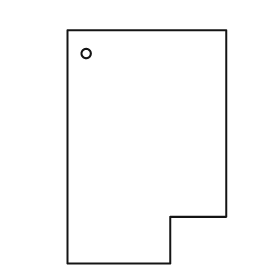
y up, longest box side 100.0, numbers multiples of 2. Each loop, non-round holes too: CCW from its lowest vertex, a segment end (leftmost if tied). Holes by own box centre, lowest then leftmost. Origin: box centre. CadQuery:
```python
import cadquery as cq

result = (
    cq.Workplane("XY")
    .moveTo(-34.0, -50.0)
    .lineTo(10.0, -50.0)
    .lineTo(10.0, -30.0)
    .lineTo(34.0, -30.0)
    .lineTo(34.0, 50.0)
    .lineTo(-34.0, 50.0)
    .close()
    .moveTo(-26.0, 40.0)
    .circle(2.0)
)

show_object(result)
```